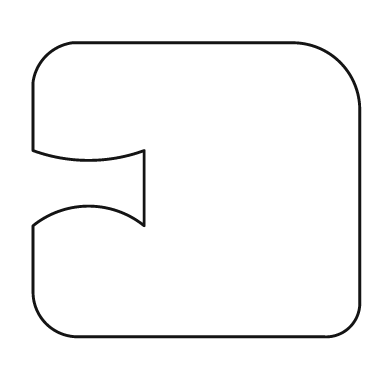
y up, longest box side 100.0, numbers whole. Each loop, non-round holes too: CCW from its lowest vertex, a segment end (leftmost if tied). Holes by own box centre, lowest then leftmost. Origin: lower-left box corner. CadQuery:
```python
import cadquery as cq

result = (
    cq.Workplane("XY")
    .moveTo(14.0, 0.0)
    .lineTo(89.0, 0.0)
    .threePointArc((97.0, 3.0), (100.0, 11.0))
    .lineTo(100.0, 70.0)
    .threePointArc((94.0, 84.0), (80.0, 90.0))
    .lineTo(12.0, 90.0)
    .threePointArc((4.0, 86.0), (0.0, 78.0))
    .lineTo(0.0, 57.0)
    .threePointArc((17.0, 54.0), (34.0, 57.0))
    .lineTo(34.0, 34.0)
    .threePointArc((17.0, 40.0), (0.0, 34.0))
    .lineTo(0.0, 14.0)
    .threePointArc((4.0, 4.0), (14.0, 0.0))
    .close()
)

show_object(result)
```